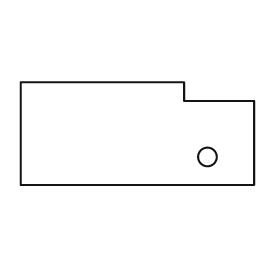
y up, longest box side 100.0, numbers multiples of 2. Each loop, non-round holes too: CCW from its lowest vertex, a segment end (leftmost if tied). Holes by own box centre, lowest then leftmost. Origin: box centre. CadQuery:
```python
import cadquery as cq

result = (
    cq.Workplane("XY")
    .moveTo(-50.0, -22.0)
    .lineTo(50.0, -22.0)
    .lineTo(50.0, 14.0)
    .lineTo(20.0, 14.0)
    .lineTo(20.0, 22.0)
    .lineTo(-50.0, 22.0)
    .close()
    .moveTo(30.0, -10.0)
    .circle(4.0)
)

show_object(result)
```